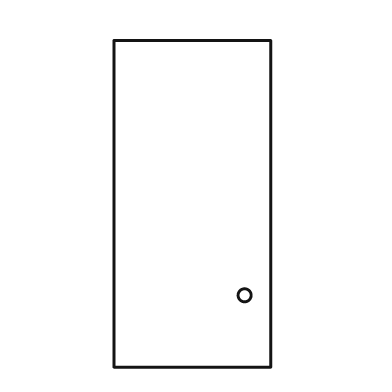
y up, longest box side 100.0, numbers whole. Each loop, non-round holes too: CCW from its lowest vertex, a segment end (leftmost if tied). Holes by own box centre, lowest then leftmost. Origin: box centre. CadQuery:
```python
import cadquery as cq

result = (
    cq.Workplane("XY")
    .moveTo(-24.0, -50.0)
    .lineTo(24.0, -50.0)
    .lineTo(24.0, 50.0)
    .lineTo(-24.0, 50.0)
    .close()
    .moveTo(16.0, -28.0)
    .circle(2.0)
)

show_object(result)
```